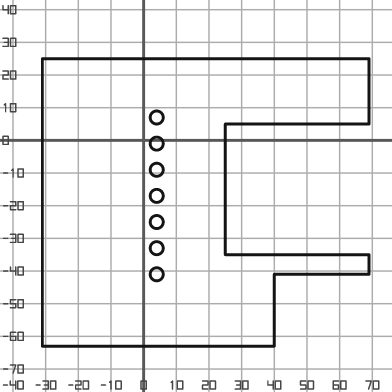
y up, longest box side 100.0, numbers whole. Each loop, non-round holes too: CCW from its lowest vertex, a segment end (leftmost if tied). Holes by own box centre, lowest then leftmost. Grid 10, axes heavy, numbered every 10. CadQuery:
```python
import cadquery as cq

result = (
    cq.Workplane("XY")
    .moveTo(-31.0, -63.0)
    .lineTo(40.0, -63.0)
    .lineTo(40.0, -41.0)
    .lineTo(69.0, -41.0)
    .lineTo(69.0, -35.0)
    .lineTo(25.0, -35.0)
    .lineTo(25.0, 5.0)
    .lineTo(69.0, 5.0)
    .lineTo(69.0, 25.0)
    .lineTo(-31.0, 25.0)
    .close()
    .moveTo(4.0, -41.0)
    .circle(2.0)
    .moveTo(4.0, -33.0)
    .circle(2.0)
    .moveTo(4.0, -25.0)
    .circle(2.0)
    .moveTo(4.0, -17.0)
    .circle(2.0)
    .moveTo(4.0, -9.0)
    .circle(2.0)
    .moveTo(4.0, -1.0)
    .circle(2.0)
    .moveTo(4.0, 7.0)
    .circle(2.0)
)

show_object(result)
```